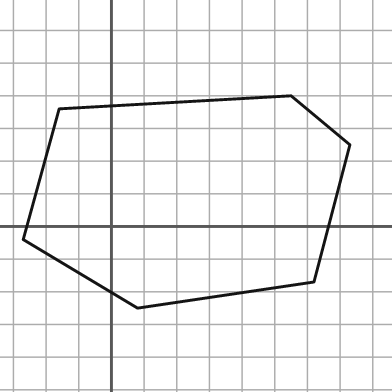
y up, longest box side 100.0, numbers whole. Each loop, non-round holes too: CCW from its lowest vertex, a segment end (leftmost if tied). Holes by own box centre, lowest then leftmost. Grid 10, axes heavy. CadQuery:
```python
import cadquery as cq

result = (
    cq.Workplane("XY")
    .moveTo(8.0, -25.0)
    .lineTo(62.0, -17.0)
    .lineTo(73.0, 25.0)
    .lineTo(55.0, 40.0)
    .lineTo(-16.0, 36.0)
    .lineTo(-27.0, -4.0)
    .close()
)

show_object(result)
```